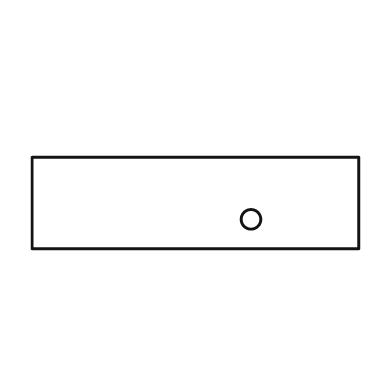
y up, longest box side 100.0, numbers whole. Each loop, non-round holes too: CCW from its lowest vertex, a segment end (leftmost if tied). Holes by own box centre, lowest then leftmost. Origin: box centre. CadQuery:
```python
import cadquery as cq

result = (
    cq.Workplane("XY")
    .moveTo(-50.0, -14.0)
    .lineTo(50.0, -14.0)
    .lineTo(50.0, 14.0)
    .lineTo(-50.0, 14.0)
    .close()
    .moveTo(17.0, -5.0)
    .circle(3.0)
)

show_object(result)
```